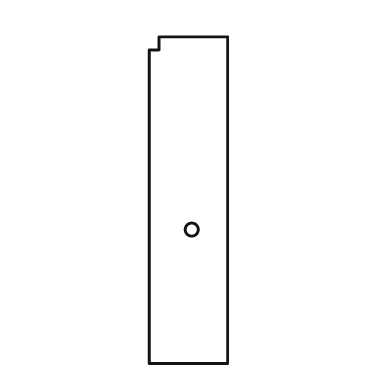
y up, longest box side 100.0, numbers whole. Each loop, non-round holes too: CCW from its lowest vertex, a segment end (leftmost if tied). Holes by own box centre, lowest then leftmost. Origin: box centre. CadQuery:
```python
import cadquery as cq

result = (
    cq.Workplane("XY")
    .moveTo(-12.0, -50.0)
    .lineTo(12.0, -50.0)
    .lineTo(12.0, 50.0)
    .lineTo(-9.0, 50.0)
    .lineTo(-9.0, 46.0)
    .lineTo(-12.0, 46.0)
    .close()
    .moveTo(1.0, -9.0)
    .circle(2.0)
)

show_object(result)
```